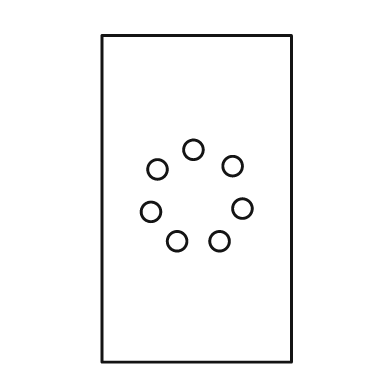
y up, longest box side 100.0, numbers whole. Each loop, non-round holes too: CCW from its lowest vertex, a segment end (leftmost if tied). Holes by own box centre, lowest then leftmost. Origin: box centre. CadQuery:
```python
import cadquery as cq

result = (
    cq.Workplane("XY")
    .moveTo(-29.0, -50.0)
    .lineTo(29.0, -50.0)
    .lineTo(29.0, 50.0)
    .lineTo(-29.0, 50.0)
    .close()
    .moveTo(-6.0, -13.0)
    .circle(3.0)
    .moveTo(7.0, -13.0)
    .circle(3.0)
    .moveTo(-14.0, -4.0)
    .circle(3.0)
    .moveTo(14.0, -3.0)
    .circle(3.0)
    .moveTo(-12.0, 9.0)
    .circle(3.0)
    .moveTo(11.0, 10.0)
    .circle(3.0)
    .moveTo(-1.0, 15.0)
    .circle(3.0)
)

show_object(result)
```